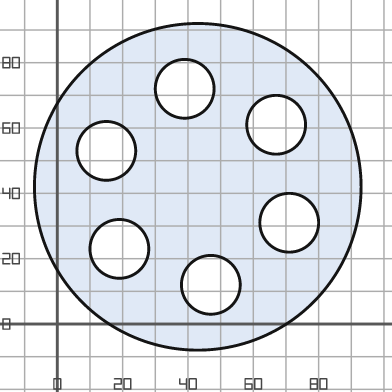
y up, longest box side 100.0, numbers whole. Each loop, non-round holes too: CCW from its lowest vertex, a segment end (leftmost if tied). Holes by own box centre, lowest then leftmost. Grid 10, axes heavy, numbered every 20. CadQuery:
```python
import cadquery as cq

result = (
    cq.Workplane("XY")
    .moveTo(43.0, 42.0)
    .circle(50.0)
    .moveTo(47.0, 12.0)
    .circle(9.0)
    .moveTo(19.0, 23.0)
    .circle(9.0)
    .moveTo(71.0, 31.0)
    .circle(9.0)
    .moveTo(15.0, 53.0)
    .circle(9.0)
    .moveTo(67.0, 61.0)
    .circle(9.0)
    .moveTo(39.0, 72.0)
    .circle(9.0)
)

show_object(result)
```